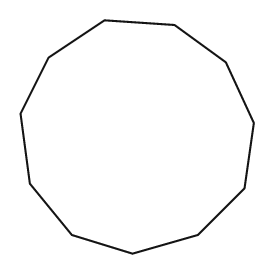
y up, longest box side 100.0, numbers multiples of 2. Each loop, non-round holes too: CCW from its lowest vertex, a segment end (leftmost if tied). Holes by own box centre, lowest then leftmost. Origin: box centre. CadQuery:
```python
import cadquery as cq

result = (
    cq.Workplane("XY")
    .moveTo(-2.0, -50.0)
    .lineTo(26.0, -42.0)
    .lineTo(46.0, -22.0)
    .lineTo(50.0, 6.0)
    .lineTo(38.0, 32.0)
    .lineTo(16.0, 48.0)
    .lineTo(-14.0, 50.0)
    .lineTo(-38.0, 34.0)
    .lineTo(-50.0, 10.0)
    .lineTo(-46.0, -20.0)
    .lineTo(-28.0, -42.0)
    .close()
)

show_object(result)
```